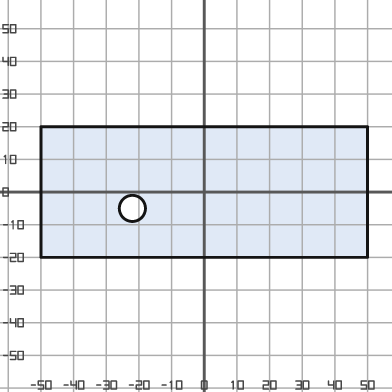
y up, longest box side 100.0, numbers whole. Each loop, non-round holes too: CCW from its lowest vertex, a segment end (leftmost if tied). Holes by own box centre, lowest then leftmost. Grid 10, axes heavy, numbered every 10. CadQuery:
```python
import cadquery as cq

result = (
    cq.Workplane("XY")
    .moveTo(-50.0, -20.0)
    .lineTo(50.0, -20.0)
    .lineTo(50.0, 20.0)
    .lineTo(-50.0, 20.0)
    .close()
    .moveTo(-22.0, -5.0)
    .circle(4.0)
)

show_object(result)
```